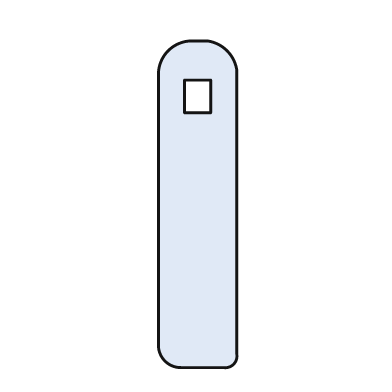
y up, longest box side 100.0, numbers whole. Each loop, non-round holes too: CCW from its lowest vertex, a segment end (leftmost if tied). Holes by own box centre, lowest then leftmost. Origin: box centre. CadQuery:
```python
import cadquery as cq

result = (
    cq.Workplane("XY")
    .moveTo(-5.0, -50.0)
    .lineTo(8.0, -50.0)
    .threePointArc((11.0, -49.0), (12.0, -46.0))
    .lineTo(12.0, 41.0)
    .threePointArc((9.0, 47.0), (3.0, 50.0))
    .lineTo(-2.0, 50.0)
    .threePointArc((-9.0, 47.0), (-12.0, 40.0))
    .lineTo(-12.0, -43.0)
    .threePointArc((-10.0, -48.0), (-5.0, -50.0))
    .close()
    .moveTo(-4.0, 28.0)
    .lineTo(4.0, 28.0)
    .lineTo(4.0, 38.0)
    .lineTo(-4.0, 38.0)
    .close()
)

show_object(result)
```